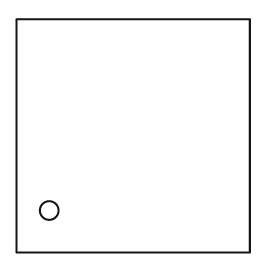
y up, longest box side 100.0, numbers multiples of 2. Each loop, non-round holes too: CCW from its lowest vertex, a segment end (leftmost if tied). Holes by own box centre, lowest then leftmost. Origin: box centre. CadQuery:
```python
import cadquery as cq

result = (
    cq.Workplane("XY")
    .moveTo(-50.0, -50.0)
    .lineTo(50.0, -50.0)
    .lineTo(50.0, 50.0)
    .lineTo(-50.0, 50.0)
    .close()
    .moveTo(-36.0, -32.0)
    .circle(4.0)
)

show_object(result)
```